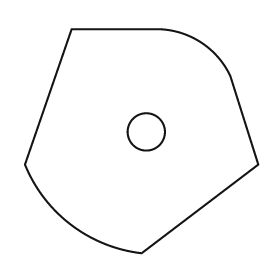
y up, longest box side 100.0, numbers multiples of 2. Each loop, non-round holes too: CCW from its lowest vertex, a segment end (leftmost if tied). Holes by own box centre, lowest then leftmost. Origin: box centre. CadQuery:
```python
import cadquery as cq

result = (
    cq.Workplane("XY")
    .moveTo(0.0, -48.0)
    .lineTo(50.0, -10.0)
    .lineTo(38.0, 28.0)
    .threePointArc((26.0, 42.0), (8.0, 48.0))
    .lineTo(-30.0, 48.0)
    .lineTo(-50.0, -10.0)
    .threePointArc((-30.0, -36.0), (0.0, -48.0))
    .close()
    .moveTo(2.0, 4.0)
    .circle(8.0)
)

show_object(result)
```